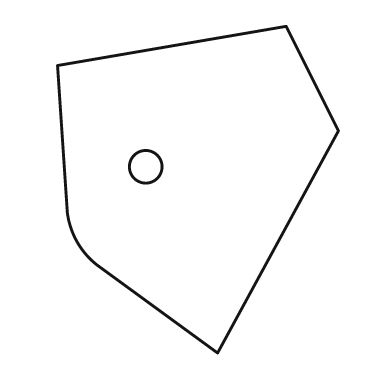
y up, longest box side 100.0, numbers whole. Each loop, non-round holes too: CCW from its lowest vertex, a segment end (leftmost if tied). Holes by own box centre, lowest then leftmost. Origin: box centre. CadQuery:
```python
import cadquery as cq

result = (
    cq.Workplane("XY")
    .moveTo(6.0, -50.0)
    .lineTo(43.0, 18.0)
    .lineTo(27.0, 50.0)
    .lineTo(-43.0, 38.0)
    .lineTo(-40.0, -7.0)
    .threePointArc((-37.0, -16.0), (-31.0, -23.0))
    .close()
    .moveTo(-16.0, 7.0)
    .circle(5.0)
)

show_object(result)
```